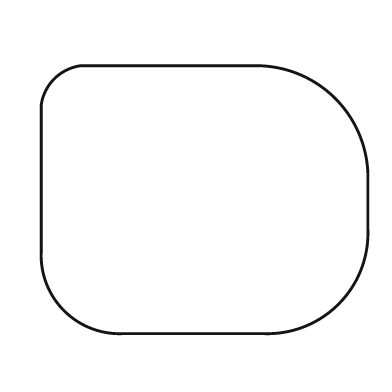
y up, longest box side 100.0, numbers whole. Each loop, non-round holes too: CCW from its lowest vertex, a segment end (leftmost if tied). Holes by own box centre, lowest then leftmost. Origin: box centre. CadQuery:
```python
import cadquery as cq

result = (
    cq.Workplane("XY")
    .moveTo(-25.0, -41.0)
    .lineTo(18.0, -41.0)
    .threePointArc((41.0, -32.0), (50.0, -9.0))
    .lineTo(50.0, 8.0)
    .threePointArc((40.0, 31.0), (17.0, 41.0))
    .lineTo(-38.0, 41.0)
    .threePointArc((-46.0, 37.0), (-50.0, 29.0))
    .lineTo(-50.0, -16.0)
    .threePointArc((-43.0, -34.0), (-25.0, -41.0))
    .close()
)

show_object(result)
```